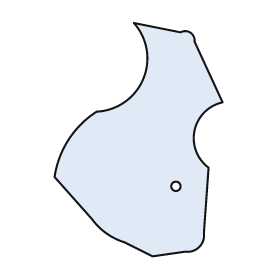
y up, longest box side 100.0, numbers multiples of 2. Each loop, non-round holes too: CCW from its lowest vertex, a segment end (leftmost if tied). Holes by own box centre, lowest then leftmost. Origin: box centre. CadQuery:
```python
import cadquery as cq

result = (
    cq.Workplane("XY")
    .moveTo(6.0, -50.0)
    .lineTo(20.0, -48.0)
    .threePointArc((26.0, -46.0), (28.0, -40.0))
    .lineTo(30.0, -12.0)
    .threePointArc((24.0, 4.0), (36.0, 16.0))
    .lineTo(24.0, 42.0)
    .threePointArc((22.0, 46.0), (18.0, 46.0))
    .lineTo(-2.0, 50.0)
    .threePointArc((2.0, 26.0), (-18.0, 12.0))
    .threePointArc((-30.0, 0.0), (-36.0, -16.0))
    .lineTo(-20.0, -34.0)
    .threePointArc((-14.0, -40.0), (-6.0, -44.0))
    .close()
    .moveTo(16.0, -20.0)
    .circle(2.0)
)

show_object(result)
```